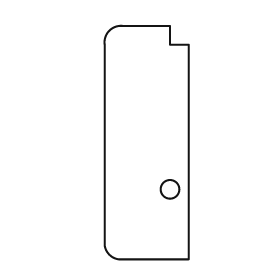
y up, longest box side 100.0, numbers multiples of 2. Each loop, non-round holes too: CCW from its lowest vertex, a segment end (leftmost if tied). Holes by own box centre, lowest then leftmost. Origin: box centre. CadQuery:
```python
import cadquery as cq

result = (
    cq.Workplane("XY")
    .moveTo(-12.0, -50.0)
    .lineTo(18.0, -50.0)
    .lineTo(18.0, 42.0)
    .lineTo(10.0, 42.0)
    .lineTo(10.0, 50.0)
    .lineTo(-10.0, 50.0)
    .threePointArc((-16.0, 48.0), (-18.0, 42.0))
    .lineTo(-18.0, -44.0)
    .threePointArc((-16.0, -48.0), (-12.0, -50.0))
    .close()
    .moveTo(10.0, -20.0)
    .circle(4.0)
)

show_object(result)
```